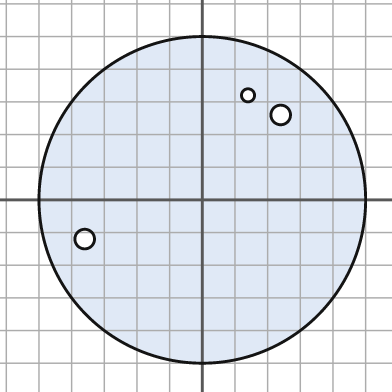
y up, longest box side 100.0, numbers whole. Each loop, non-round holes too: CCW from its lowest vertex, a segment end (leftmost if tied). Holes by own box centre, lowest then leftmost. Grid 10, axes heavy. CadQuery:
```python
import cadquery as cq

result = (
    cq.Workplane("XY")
    .moveTo(0.0, 0.0)
    .circle(50.0)
    .moveTo(-36.0, -12.0)
    .circle(3.0)
    .moveTo(24.0, 26.0)
    .circle(3.0)
    .moveTo(14.0, 32.0)
    .circle(2.0)
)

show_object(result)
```